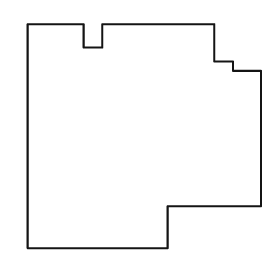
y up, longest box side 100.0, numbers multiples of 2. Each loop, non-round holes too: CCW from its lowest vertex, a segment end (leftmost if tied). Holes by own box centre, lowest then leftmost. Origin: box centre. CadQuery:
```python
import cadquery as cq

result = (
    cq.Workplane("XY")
    .moveTo(-50.0, -48.0)
    .lineTo(10.0, -48.0)
    .lineTo(10.0, -30.0)
    .lineTo(50.0, -30.0)
    .lineTo(50.0, 28.0)
    .lineTo(38.0, 28.0)
    .lineTo(38.0, 32.0)
    .lineTo(30.0, 32.0)
    .lineTo(30.0, 48.0)
    .lineTo(-18.0, 48.0)
    .lineTo(-18.0, 38.0)
    .lineTo(-26.0, 38.0)
    .lineTo(-26.0, 48.0)
    .lineTo(-50.0, 48.0)
    .close()
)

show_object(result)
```